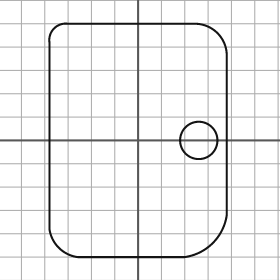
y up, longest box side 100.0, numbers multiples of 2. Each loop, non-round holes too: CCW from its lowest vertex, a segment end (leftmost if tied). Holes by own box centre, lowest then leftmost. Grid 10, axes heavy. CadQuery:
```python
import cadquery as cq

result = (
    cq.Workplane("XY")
    .moveTo(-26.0, -50.0)
    .lineTo(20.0, -50.0)
    .threePointArc((32.0, -44.0), (38.0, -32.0))
    .lineTo(38.0, 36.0)
    .threePointArc((34.0, 46.0), (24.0, 50.0))
    .lineTo(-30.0, 50.0)
    .threePointArc((-36.0, 48.0), (-38.0, 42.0))
    .lineTo(-38.0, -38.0)
    .threePointArc((-34.0, -46.0), (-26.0, -50.0))
    .close()
    .moveTo(26.0, 0.0)
    .circle(8.0)
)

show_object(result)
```